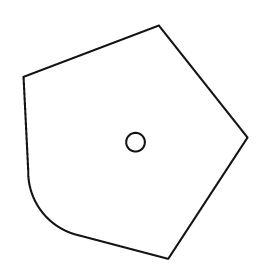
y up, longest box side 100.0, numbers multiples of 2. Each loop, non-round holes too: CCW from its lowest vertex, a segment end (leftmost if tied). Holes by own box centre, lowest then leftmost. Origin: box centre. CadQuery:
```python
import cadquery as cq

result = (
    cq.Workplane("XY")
    .moveTo(14.0, -50.0)
    .lineTo(48.0, 2.0)
    .lineTo(10.0, 50.0)
    .lineTo(-48.0, 28.0)
    .lineTo(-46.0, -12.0)
    .threePointArc((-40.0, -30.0), (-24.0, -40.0))
    .close()
    .moveTo(0.0, 0.0)
    .circle(4.0)
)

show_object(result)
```